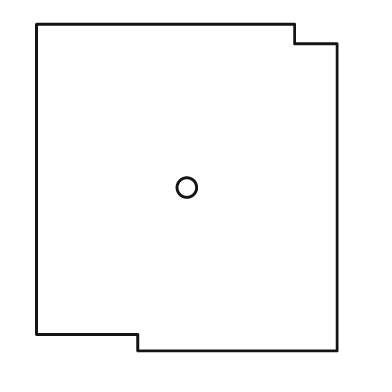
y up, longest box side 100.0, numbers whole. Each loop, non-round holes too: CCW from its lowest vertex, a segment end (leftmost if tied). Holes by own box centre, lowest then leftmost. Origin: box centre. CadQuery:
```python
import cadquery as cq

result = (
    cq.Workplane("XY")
    .moveTo(-15.0, -50.0)
    .lineTo(46.0, -50.0)
    .lineTo(46.0, 44.0)
    .lineTo(33.0, 44.0)
    .lineTo(33.0, 50.0)
    .lineTo(-46.0, 50.0)
    .lineTo(-46.0, -45.0)
    .lineTo(-15.0, -45.0)
    .close()
    .moveTo(0.0, 0.0)
    .circle(3.0)
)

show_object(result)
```